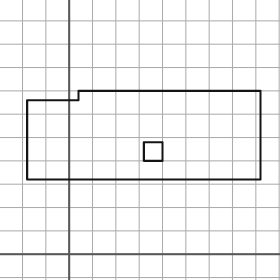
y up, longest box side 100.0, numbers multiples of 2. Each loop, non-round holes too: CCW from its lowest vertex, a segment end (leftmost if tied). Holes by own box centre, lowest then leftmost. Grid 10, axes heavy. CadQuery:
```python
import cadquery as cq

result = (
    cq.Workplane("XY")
    .moveTo(-18.0, 32.0)
    .lineTo(82.0, 32.0)
    .lineTo(82.0, 70.0)
    .lineTo(4.0, 70.0)
    .lineTo(4.0, 66.0)
    .lineTo(-18.0, 66.0)
    .close()
    .moveTo(32.0, 40.0)
    .lineTo(40.0, 40.0)
    .lineTo(40.0, 48.0)
    .lineTo(32.0, 48.0)
    .close()
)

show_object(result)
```